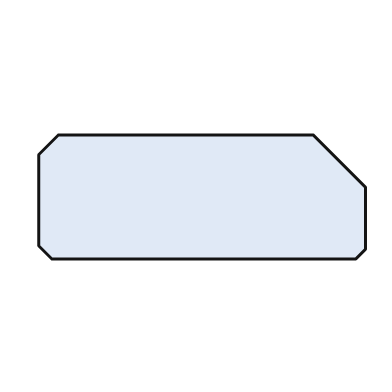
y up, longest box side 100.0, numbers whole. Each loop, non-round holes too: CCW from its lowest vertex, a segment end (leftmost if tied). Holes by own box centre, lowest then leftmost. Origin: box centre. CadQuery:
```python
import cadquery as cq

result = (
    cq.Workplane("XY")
    .moveTo(-46.0, -19.0)
    .lineTo(47.0, -19.0)
    .lineTo(50.0, -16.0)
    .lineTo(50.0, 3.0)
    .lineTo(34.0, 19.0)
    .lineTo(-44.0, 19.0)
    .lineTo(-50.0, 13.0)
    .lineTo(-50.0, -15.0)
    .close()
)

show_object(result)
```